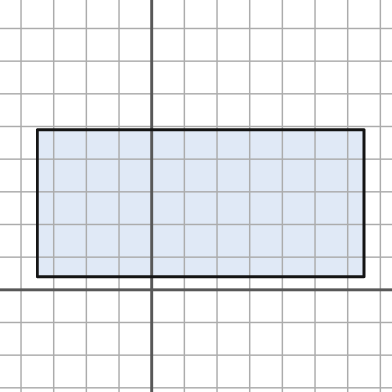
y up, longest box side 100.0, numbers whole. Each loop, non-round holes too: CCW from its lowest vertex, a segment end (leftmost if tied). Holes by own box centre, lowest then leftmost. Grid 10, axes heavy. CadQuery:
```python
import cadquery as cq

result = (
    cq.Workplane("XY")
    .moveTo(-35.0, 4.0)
    .lineTo(65.0, 4.0)
    .lineTo(65.0, 49.0)
    .lineTo(-35.0, 49.0)
    .close()
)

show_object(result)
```